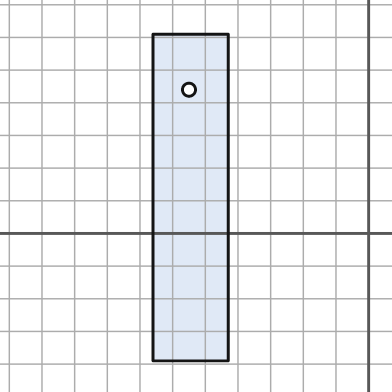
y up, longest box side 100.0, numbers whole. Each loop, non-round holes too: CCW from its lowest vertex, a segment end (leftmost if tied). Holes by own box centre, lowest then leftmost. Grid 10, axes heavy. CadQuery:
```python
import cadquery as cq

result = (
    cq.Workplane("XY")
    .moveTo(-66.0, -39.0)
    .lineTo(-43.0, -39.0)
    .lineTo(-43.0, 61.0)
    .lineTo(-66.0, 61.0)
    .close()
    .moveTo(-55.0, 44.0)
    .circle(2.0)
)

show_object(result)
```